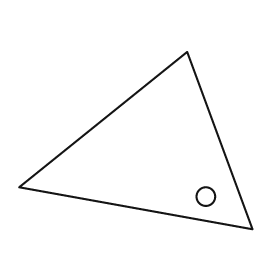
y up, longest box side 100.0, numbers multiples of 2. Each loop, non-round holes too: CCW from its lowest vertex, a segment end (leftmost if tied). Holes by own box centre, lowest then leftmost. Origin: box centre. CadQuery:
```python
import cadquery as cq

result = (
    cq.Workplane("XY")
    .moveTo(50.0, -38.0)
    .lineTo(22.0, 38.0)
    .lineTo(-50.0, -20.0)
    .close()
    .moveTo(30.0, -24.0)
    .circle(4.0)
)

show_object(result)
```